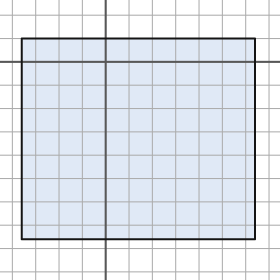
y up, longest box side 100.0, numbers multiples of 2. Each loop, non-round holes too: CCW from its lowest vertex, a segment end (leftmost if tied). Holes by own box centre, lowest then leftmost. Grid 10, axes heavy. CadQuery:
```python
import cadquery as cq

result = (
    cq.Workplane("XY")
    .moveTo(-36.0, -76.0)
    .lineTo(64.0, -76.0)
    .lineTo(64.0, 10.0)
    .lineTo(-36.0, 10.0)
    .close()
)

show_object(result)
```